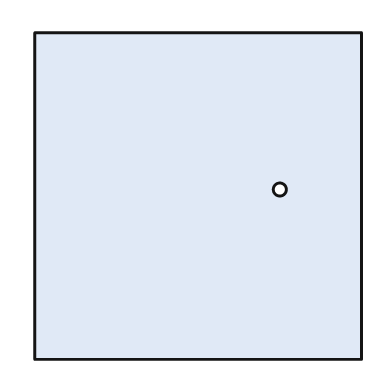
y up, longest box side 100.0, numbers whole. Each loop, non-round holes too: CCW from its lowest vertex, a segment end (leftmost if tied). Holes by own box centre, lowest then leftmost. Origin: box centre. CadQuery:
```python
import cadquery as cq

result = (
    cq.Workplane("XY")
    .moveTo(-50.0, -50.0)
    .lineTo(50.0, -50.0)
    .lineTo(50.0, 50.0)
    .lineTo(-50.0, 50.0)
    .close()
    .moveTo(25.0, 2.0)
    .circle(2.0)
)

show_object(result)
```